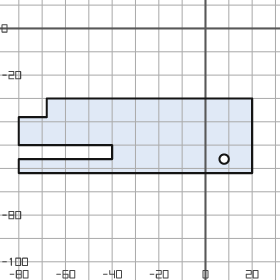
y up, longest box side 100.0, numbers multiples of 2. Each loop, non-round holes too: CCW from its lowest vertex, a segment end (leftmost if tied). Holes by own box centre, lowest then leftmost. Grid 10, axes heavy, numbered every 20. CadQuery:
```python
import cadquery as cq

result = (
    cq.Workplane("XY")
    .moveTo(-80.0, -62.0)
    .lineTo(20.0, -62.0)
    .lineTo(20.0, -30.0)
    .lineTo(-68.0, -30.0)
    .lineTo(-68.0, -38.0)
    .lineTo(-80.0, -38.0)
    .lineTo(-80.0, -50.0)
    .lineTo(-40.0, -50.0)
    .lineTo(-40.0, -56.0)
    .lineTo(-80.0, -56.0)
    .close()
    .moveTo(8.0, -56.0)
    .circle(2.0)
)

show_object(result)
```